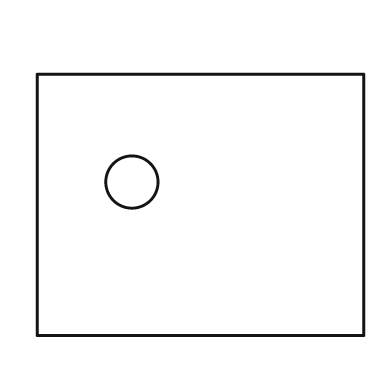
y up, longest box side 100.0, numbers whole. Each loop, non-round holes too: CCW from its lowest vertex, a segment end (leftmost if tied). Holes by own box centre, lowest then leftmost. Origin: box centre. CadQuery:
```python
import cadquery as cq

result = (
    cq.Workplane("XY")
    .moveTo(-50.0, -40.0)
    .lineTo(50.0, -40.0)
    .lineTo(50.0, 40.0)
    .lineTo(-50.0, 40.0)
    .close()
    .moveTo(-21.0, 7.0)
    .circle(8.0)
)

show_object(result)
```